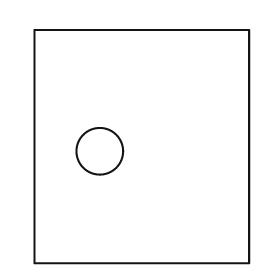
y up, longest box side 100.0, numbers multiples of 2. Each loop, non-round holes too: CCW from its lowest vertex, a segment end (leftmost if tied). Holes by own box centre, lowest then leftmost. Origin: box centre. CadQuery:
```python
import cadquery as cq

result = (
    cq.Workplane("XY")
    .moveTo(-46.0, -50.0)
    .lineTo(46.0, -50.0)
    .lineTo(46.0, 50.0)
    .lineTo(-46.0, 50.0)
    .close()
    .moveTo(-18.0, -2.0)
    .circle(10.0)
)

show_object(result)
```